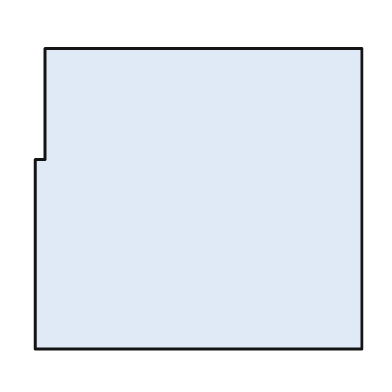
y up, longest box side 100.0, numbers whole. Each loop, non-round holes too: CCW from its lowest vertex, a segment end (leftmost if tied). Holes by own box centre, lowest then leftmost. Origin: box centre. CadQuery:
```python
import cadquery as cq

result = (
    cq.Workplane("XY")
    .moveTo(-50.0, -46.0)
    .lineTo(50.0, -46.0)
    .lineTo(50.0, 46.0)
    .lineTo(-47.0, 46.0)
    .lineTo(-47.0, 12.0)
    .lineTo(-50.0, 12.0)
    .close()
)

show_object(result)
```